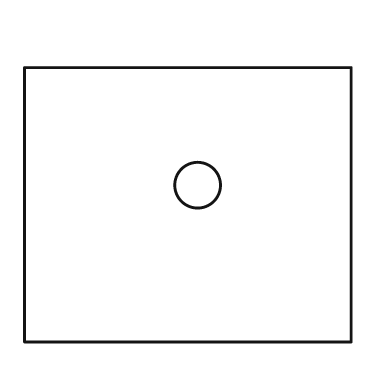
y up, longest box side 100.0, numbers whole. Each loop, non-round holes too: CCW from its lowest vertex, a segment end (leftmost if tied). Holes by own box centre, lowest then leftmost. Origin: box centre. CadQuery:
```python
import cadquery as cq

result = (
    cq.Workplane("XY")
    .moveTo(-50.0, -42.0)
    .lineTo(50.0, -42.0)
    .lineTo(50.0, 42.0)
    .lineTo(-50.0, 42.0)
    .close()
    .moveTo(3.0, 6.0)
    .circle(7.0)
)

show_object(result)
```